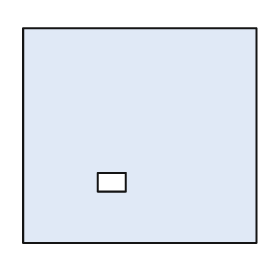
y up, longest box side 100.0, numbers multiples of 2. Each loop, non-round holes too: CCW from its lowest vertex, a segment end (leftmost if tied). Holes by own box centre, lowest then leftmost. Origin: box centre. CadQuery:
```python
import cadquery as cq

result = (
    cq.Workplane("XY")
    .moveTo(-50.0, -46.0)
    .lineTo(50.0, -46.0)
    .lineTo(50.0, 46.0)
    .lineTo(-50.0, 46.0)
    .close()
    .moveTo(-18.0, -24.0)
    .lineTo(-6.0, -24.0)
    .lineTo(-6.0, -16.0)
    .lineTo(-18.0, -16.0)
    .close()
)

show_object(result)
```